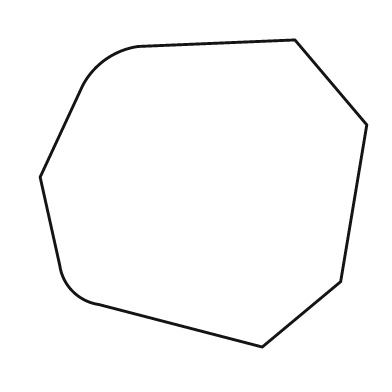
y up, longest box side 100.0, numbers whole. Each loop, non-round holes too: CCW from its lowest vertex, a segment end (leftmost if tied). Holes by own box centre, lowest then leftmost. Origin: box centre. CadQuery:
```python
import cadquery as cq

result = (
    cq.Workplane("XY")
    .moveTo(18.0, -47.0)
    .lineTo(42.0, -27.0)
    .lineTo(50.0, 21.0)
    .lineTo(28.0, 47.0)
    .lineTo(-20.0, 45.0)
    .threePointArc((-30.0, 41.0), (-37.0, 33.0))
    .lineTo(-50.0, 5.0)
    .lineTo(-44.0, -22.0)
    .threePointArc((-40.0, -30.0), (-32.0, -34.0))
    .close()
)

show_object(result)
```